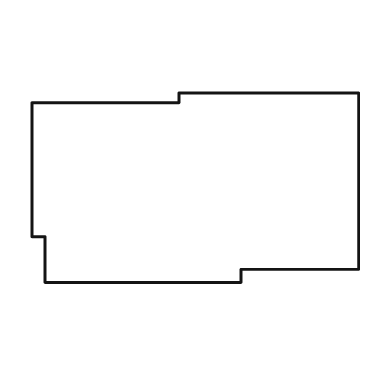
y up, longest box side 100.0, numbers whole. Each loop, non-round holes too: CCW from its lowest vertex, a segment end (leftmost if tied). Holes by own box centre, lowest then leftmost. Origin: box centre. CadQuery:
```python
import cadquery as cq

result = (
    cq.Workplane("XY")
    .moveTo(-46.0, -29.0)
    .lineTo(14.0, -29.0)
    .lineTo(14.0, -25.0)
    .lineTo(50.0, -25.0)
    .lineTo(50.0, 29.0)
    .lineTo(-5.0, 29.0)
    .lineTo(-5.0, 26.0)
    .lineTo(-50.0, 26.0)
    .lineTo(-50.0, -15.0)
    .lineTo(-46.0, -15.0)
    .close()
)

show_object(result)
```